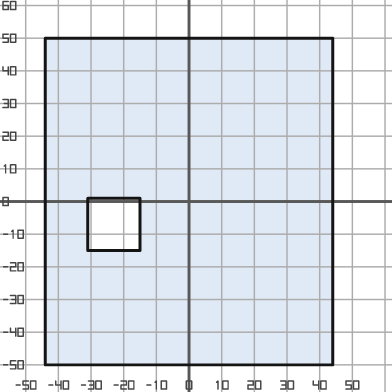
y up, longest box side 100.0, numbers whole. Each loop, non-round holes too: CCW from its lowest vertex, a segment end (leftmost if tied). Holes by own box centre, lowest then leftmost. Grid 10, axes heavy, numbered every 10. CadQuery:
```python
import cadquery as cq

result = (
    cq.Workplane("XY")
    .moveTo(-44.0, -50.0)
    .lineTo(44.0, -50.0)
    .lineTo(44.0, 50.0)
    .lineTo(-44.0, 50.0)
    .close()
    .moveTo(-31.0, -15.0)
    .lineTo(-15.0, -15.0)
    .lineTo(-15.0, 1.0)
    .lineTo(-31.0, 1.0)
    .close()
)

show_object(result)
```